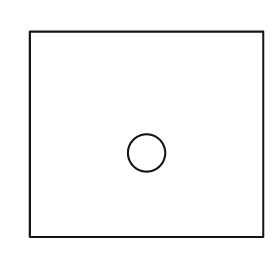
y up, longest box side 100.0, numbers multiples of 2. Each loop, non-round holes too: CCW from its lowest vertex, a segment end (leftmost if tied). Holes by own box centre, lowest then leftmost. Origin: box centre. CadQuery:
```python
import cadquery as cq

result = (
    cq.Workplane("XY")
    .moveTo(-50.0, -44.0)
    .lineTo(50.0, -44.0)
    .lineTo(50.0, 44.0)
    .lineTo(-50.0, 44.0)
    .close()
    .moveTo(0.0, -8.0)
    .circle(8.0)
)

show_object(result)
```